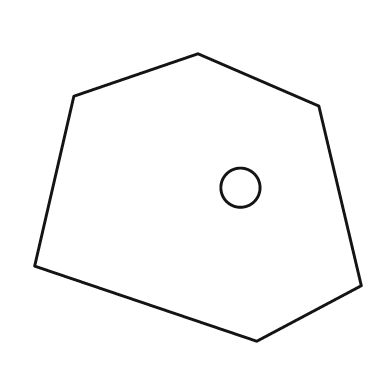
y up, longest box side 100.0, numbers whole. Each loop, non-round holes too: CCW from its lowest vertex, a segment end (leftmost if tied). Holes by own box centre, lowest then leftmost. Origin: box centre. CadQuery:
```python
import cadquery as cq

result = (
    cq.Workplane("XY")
    .moveTo(18.0, -44.0)
    .lineTo(50.0, -27.0)
    .lineTo(37.0, 28.0)
    .lineTo(0.0, 44.0)
    .lineTo(-38.0, 31.0)
    .lineTo(-50.0, -21.0)
    .close()
    .moveTo(13.0, 3.0)
    .circle(6.0)
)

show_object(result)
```